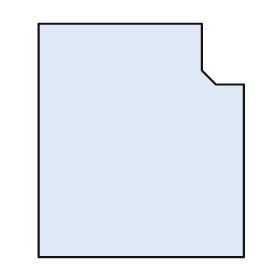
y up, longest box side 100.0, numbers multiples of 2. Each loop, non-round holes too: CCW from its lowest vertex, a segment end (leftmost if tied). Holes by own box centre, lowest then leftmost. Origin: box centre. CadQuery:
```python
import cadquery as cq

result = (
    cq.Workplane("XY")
    .moveTo(-44.0, -50.0)
    .lineTo(44.0, -50.0)
    .lineTo(44.0, 24.0)
    .lineTo(32.0, 24.0)
    .lineTo(26.0, 30.0)
    .lineTo(26.0, 50.0)
    .lineTo(-44.0, 50.0)
    .close()
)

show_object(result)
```